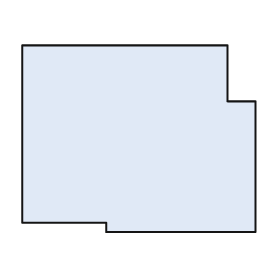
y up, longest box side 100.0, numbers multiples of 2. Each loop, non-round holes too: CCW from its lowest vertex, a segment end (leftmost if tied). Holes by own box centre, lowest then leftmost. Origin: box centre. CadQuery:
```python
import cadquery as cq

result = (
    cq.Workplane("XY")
    .moveTo(-14.0, -40.0)
    .lineTo(50.0, -40.0)
    .lineTo(50.0, 16.0)
    .lineTo(38.0, 16.0)
    .lineTo(38.0, 40.0)
    .lineTo(-50.0, 40.0)
    .lineTo(-50.0, -36.0)
    .lineTo(-14.0, -36.0)
    .close()
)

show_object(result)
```